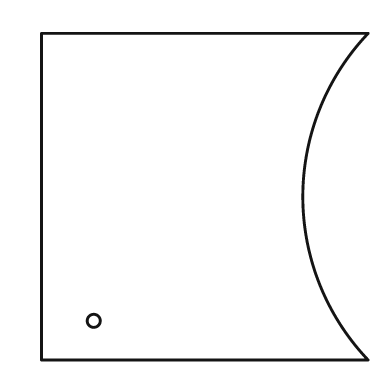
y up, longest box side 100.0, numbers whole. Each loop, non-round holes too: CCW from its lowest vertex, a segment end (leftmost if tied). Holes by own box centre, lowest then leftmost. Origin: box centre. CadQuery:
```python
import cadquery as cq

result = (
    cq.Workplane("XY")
    .moveTo(-50.0, -50.0)
    .lineTo(50.0, -50.0)
    .threePointArc((30.0, 0.0), (50.0, 50.0))
    .lineTo(-50.0, 50.0)
    .close()
    .moveTo(-34.0, -38.0)
    .circle(2.0)
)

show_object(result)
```